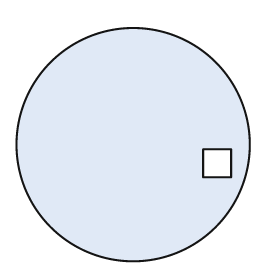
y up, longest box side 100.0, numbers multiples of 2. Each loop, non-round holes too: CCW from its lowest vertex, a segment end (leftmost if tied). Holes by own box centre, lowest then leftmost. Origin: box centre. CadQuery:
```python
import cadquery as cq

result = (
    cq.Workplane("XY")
    .moveTo(0.0, 0.0)
    .circle(50.0)
    .moveTo(30.0, -14.0)
    .lineTo(42.0, -14.0)
    .lineTo(42.0, -2.0)
    .lineTo(30.0, -2.0)
    .close()
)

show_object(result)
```